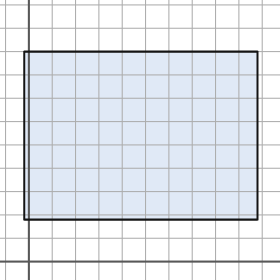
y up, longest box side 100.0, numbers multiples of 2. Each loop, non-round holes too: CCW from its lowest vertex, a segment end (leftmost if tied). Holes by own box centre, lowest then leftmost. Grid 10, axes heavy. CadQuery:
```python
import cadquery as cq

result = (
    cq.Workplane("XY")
    .moveTo(-2.0, 18.0)
    .lineTo(98.0, 18.0)
    .lineTo(98.0, 90.0)
    .lineTo(-2.0, 90.0)
    .close()
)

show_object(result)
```